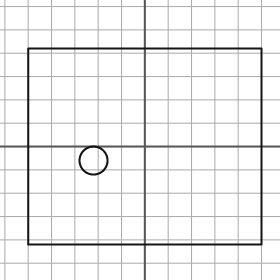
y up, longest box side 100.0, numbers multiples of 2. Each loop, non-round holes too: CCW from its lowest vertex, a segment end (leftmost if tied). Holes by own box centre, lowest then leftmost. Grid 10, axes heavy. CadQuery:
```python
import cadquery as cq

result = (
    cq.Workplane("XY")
    .moveTo(-50.0, -42.0)
    .lineTo(50.0, -42.0)
    .lineTo(50.0, 42.0)
    .lineTo(-50.0, 42.0)
    .close()
    .moveTo(-22.0, -6.0)
    .circle(6.0)
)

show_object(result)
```